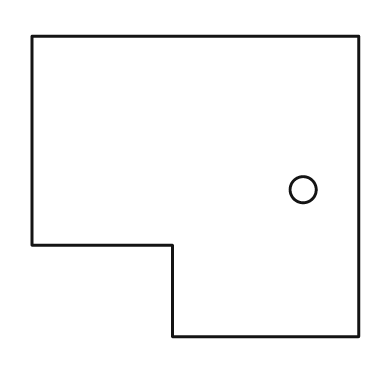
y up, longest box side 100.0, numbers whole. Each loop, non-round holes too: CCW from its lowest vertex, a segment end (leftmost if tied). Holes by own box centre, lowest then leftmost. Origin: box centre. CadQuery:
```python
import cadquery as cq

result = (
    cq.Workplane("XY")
    .moveTo(-7.0, -46.0)
    .lineTo(50.0, -46.0)
    .lineTo(50.0, 46.0)
    .lineTo(-50.0, 46.0)
    .lineTo(-50.0, -18.0)
    .lineTo(-7.0, -18.0)
    .close()
    .moveTo(33.0, -1.0)
    .circle(4.0)
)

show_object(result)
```